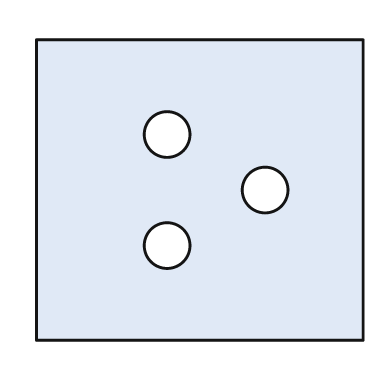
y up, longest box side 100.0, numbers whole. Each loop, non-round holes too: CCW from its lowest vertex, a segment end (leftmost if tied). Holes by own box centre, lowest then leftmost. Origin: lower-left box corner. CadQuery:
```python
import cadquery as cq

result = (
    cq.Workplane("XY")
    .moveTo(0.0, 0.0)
    .lineTo(100.0, 0.0)
    .lineTo(100.0, 92.0)
    .lineTo(0.0, 92.0)
    .close()
    .moveTo(40.0, 29.0)
    .circle(7.0)
    .moveTo(70.0, 46.0)
    .circle(7.0)
    .moveTo(40.0, 63.0)
    .circle(7.0)
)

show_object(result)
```